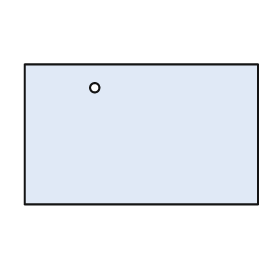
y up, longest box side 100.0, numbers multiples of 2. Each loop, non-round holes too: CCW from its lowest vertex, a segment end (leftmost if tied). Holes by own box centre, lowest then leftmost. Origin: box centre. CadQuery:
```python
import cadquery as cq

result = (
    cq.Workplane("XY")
    .moveTo(-50.0, -30.0)
    .lineTo(50.0, -30.0)
    .lineTo(50.0, 30.0)
    .lineTo(-50.0, 30.0)
    .close()
    .moveTo(-20.0, 20.0)
    .circle(2.0)
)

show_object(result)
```